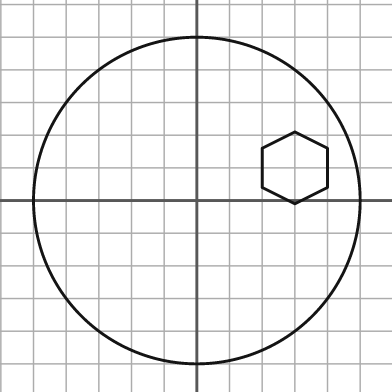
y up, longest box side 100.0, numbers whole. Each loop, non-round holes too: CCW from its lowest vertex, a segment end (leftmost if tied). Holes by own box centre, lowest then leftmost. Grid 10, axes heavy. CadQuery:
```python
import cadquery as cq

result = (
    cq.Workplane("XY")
    .moveTo(0.0, 0.0)
    .circle(50.0)
    .moveTo(30.0, -1.0)
    .lineTo(40.0, 4.0)
    .lineTo(40.0, 16.0)
    .lineTo(30.0, 21.0)
    .lineTo(20.0, 16.0)
    .lineTo(20.0, 4.0)
    .close()
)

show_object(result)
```